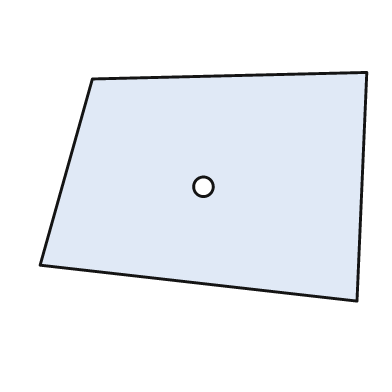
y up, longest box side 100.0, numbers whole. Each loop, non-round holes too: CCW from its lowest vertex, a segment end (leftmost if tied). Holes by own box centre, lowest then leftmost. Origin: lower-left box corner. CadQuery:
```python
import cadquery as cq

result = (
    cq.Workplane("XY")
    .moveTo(97.0, 0.0)
    .lineTo(100.0, 70.0)
    .lineTo(16.0, 68.0)
    .lineTo(0.0, 11.0)
    .close()
    .moveTo(50.0, 35.0)
    .circle(3.0)
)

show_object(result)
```